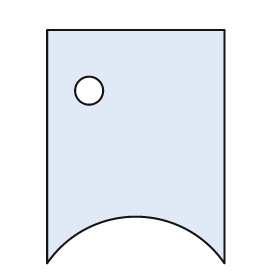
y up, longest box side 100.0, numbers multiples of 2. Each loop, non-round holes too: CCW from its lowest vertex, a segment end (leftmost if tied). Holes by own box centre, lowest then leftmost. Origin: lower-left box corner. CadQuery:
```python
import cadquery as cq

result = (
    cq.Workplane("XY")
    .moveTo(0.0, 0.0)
    .threePointArc((38.0, 20.0), (76.0, 0.0))
    .lineTo(76.0, 100.0)
    .lineTo(0.0, 100.0)
    .close()
    .moveTo(18.0, 74.0)
    .circle(6.0)
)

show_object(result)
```